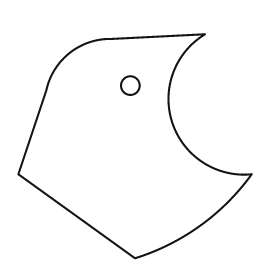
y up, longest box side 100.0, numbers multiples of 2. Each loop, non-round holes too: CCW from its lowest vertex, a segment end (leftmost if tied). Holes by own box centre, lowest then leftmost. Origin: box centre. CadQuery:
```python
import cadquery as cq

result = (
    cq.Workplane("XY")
    .moveTo(0.0, -48.0)
    .threePointArc((28.0, -34.0), (50.0, -12.0))
    .threePointArc((16.0, 10.0), (30.0, 48.0))
    .lineTo(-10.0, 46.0)
    .threePointArc((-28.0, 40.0), (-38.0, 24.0))
    .lineTo(-50.0, -12.0)
    .close()
    .moveTo(-2.0, 26.0)
    .circle(4.0)
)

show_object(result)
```